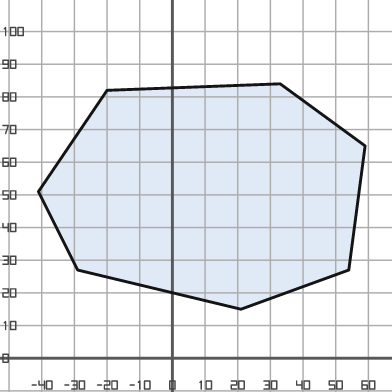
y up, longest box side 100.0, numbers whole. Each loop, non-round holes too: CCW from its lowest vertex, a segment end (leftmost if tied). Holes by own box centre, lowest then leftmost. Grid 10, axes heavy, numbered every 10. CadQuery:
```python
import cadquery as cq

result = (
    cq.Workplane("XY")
    .moveTo(21.0, 15.0)
    .lineTo(54.0, 27.0)
    .lineTo(59.0, 65.0)
    .lineTo(33.0, 84.0)
    .lineTo(-20.0, 82.0)
    .lineTo(-41.0, 51.0)
    .lineTo(-29.0, 27.0)
    .close()
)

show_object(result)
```